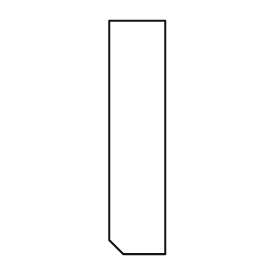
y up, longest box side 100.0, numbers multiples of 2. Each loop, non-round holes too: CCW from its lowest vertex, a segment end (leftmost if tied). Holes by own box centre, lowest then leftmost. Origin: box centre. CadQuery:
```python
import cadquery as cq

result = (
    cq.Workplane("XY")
    .moveTo(-6.0, -50.0)
    .lineTo(12.0, -50.0)
    .lineTo(12.0, 50.0)
    .lineTo(-12.0, 50.0)
    .lineTo(-12.0, -44.0)
    .close()
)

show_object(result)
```